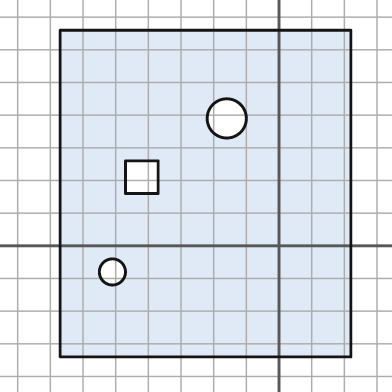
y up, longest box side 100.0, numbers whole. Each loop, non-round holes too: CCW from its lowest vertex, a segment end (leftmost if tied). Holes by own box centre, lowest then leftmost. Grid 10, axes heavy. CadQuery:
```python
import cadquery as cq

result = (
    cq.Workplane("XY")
    .moveTo(-67.0, -34.0)
    .lineTo(22.0, -34.0)
    .lineTo(22.0, 66.0)
    .lineTo(-67.0, 66.0)
    .close()
    .moveTo(-51.0, -8.0)
    .circle(4.0)
    .moveTo(-47.0, 16.0)
    .lineTo(-37.0, 16.0)
    .lineTo(-37.0, 26.0)
    .lineTo(-47.0, 26.0)
    .close()
    .moveTo(-16.0, 39.0)
    .circle(6.0)
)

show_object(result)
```